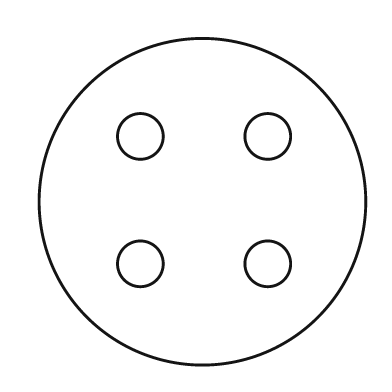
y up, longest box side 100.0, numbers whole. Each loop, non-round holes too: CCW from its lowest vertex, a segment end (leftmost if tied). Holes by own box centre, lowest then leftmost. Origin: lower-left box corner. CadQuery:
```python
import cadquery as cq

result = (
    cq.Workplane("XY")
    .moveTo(50.0, 50.0)
    .circle(50.0)
    .moveTo(31.0, 31.0)
    .circle(7.0)
    .moveTo(70.0, 31.0)
    .circle(7.0)
    .moveTo(31.0, 70.0)
    .circle(7.0)
    .moveTo(70.0, 70.0)
    .circle(7.0)
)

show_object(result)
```